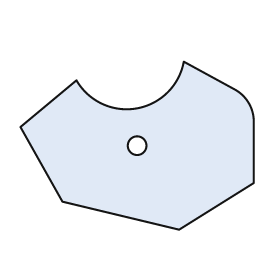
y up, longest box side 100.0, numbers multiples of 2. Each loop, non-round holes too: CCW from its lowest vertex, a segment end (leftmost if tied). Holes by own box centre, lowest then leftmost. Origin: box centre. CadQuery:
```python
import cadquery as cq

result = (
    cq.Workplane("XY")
    .moveTo(18.0, -36.0)
    .lineTo(50.0, -16.0)
    .lineTo(50.0, 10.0)
    .threePointArc((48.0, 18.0), (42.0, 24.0))
    .lineTo(20.0, 36.0)
    .threePointArc((0.0, 16.0), (-26.0, 28.0))
    .lineTo(-50.0, 8.0)
    .lineTo(-32.0, -24.0)
    .close()
    .moveTo(0.0, 0.0)
    .circle(4.0)
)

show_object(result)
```